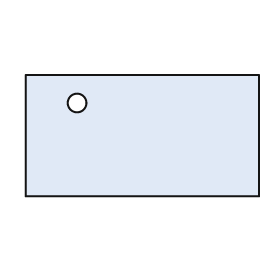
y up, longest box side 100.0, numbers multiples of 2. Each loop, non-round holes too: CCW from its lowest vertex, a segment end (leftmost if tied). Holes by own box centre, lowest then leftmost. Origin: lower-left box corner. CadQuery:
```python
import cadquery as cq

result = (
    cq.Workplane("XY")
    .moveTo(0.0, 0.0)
    .lineTo(100.0, 0.0)
    .lineTo(100.0, 52.0)
    .lineTo(0.0, 52.0)
    .close()
    .moveTo(22.0, 40.0)
    .circle(4.0)
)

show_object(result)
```